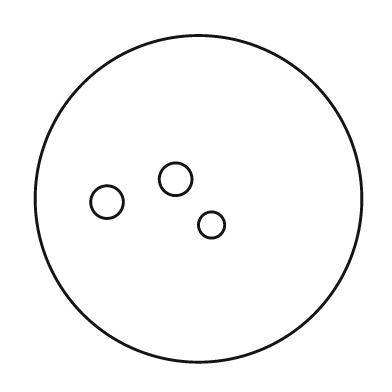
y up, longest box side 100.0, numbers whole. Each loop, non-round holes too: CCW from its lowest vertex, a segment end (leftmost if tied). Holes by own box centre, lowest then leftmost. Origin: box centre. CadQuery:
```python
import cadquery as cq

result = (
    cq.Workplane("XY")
    .moveTo(0.0, 0.0)
    .circle(50.0)
    .moveTo(4.0, -8.0)
    .circle(4.0)
    .moveTo(-28.0, -1.0)
    .circle(5.0)
    .moveTo(-7.0, 6.0)
    .circle(5.0)
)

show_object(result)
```